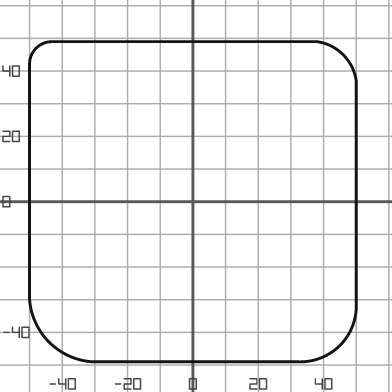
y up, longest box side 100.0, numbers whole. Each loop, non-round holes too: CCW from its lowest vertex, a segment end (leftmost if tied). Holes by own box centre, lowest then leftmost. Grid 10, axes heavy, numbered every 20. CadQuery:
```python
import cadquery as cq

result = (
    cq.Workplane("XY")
    .moveTo(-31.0, -49.0)
    .lineTo(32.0, -49.0)
    .threePointArc((45.0, -44.0), (50.0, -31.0))
    .lineTo(50.0, 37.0)
    .threePointArc((46.0, 45.0), (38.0, 49.0))
    .lineTo(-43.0, 49.0)
    .threePointArc((-48.0, 47.0), (-50.0, 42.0))
    .lineTo(-50.0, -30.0)
    .threePointArc((-44.0, -43.0), (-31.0, -49.0))
    .close()
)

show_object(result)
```